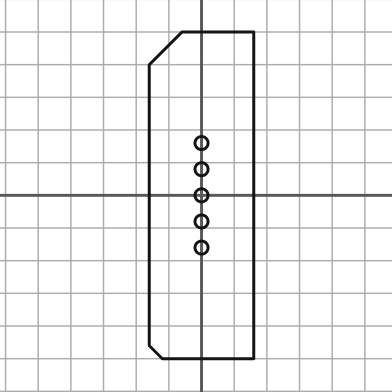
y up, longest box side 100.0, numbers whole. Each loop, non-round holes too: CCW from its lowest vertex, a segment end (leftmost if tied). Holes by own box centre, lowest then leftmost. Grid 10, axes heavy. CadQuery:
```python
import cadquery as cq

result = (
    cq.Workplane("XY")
    .moveTo(-12.0, -50.0)
    .lineTo(16.0, -50.0)
    .lineTo(16.0, 50.0)
    .lineTo(-6.0, 50.0)
    .lineTo(-16.0, 40.0)
    .lineTo(-16.0, -46.0)
    .close()
    .moveTo(0.0, -16.0)
    .circle(2.0)
    .moveTo(0.0, -8.0)
    .circle(2.0)
    .moveTo(0.0, 0.0)
    .circle(2.0)
    .moveTo(0.0, 8.0)
    .circle(2.0)
    .moveTo(0.0, 16.0)
    .circle(2.0)
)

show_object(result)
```